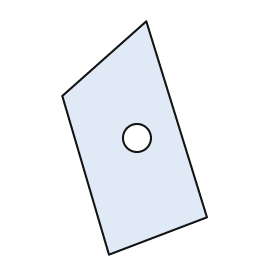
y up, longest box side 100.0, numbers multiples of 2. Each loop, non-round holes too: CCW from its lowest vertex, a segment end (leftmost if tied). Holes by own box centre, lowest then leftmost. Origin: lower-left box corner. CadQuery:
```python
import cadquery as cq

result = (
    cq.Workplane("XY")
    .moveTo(20.0, 0.0)
    .lineTo(62.0, 16.0)
    .lineTo(36.0, 100.0)
    .lineTo(0.0, 68.0)
    .close()
    .moveTo(32.0, 50.0)
    .circle(6.0)
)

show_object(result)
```